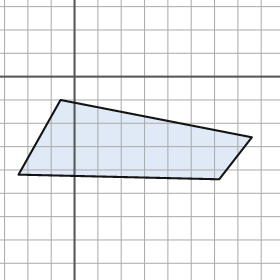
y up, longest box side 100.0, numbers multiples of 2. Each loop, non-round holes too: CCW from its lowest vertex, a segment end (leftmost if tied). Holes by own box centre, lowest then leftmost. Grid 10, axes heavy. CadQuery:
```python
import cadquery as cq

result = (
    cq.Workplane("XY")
    .moveTo(62.0, -44.0)
    .lineTo(76.0, -26.0)
    .lineTo(-6.0, -10.0)
    .lineTo(-24.0, -42.0)
    .close()
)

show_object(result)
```